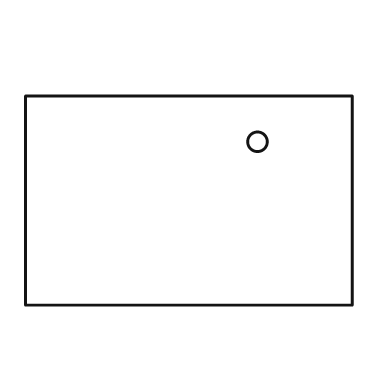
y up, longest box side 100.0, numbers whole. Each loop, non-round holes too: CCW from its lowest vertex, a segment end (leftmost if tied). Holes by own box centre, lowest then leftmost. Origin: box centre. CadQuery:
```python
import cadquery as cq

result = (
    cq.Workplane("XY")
    .moveTo(-50.0, -32.0)
    .lineTo(50.0, -32.0)
    .lineTo(50.0, 32.0)
    .lineTo(-50.0, 32.0)
    .close()
    .moveTo(21.0, 18.0)
    .circle(3.0)
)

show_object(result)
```